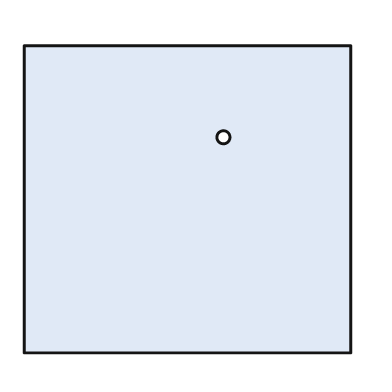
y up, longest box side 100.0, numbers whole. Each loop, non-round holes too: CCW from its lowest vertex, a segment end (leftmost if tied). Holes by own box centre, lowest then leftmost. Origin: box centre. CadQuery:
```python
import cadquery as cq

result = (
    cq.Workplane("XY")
    .moveTo(-50.0, -47.0)
    .lineTo(50.0, -47.0)
    .lineTo(50.0, 47.0)
    .lineTo(-50.0, 47.0)
    .close()
    .moveTo(11.0, 19.0)
    .circle(2.0)
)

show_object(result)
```